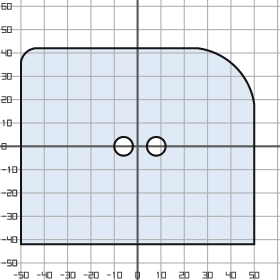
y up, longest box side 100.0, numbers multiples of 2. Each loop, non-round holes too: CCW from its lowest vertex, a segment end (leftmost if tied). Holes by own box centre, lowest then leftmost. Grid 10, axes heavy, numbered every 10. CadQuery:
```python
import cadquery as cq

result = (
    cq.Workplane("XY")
    .moveTo(-50.0, -42.0)
    .lineTo(50.0, -42.0)
    .lineTo(50.0, 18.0)
    .threePointArc((42.0, 34.0), (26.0, 42.0))
    .lineTo(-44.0, 42.0)
    .threePointArc((-48.0, 40.0), (-50.0, 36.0))
    .close()
    .moveTo(-6.0, 0.0)
    .circle(4.0)
    .moveTo(8.0, 0.0)
    .circle(4.0)
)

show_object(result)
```